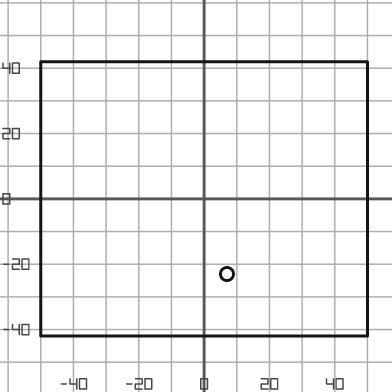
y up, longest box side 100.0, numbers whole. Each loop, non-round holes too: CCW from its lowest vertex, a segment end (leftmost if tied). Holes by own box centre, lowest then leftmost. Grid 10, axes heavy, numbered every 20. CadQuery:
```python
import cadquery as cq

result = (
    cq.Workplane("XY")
    .moveTo(-50.0, -42.0)
    .lineTo(50.0, -42.0)
    .lineTo(50.0, 42.0)
    .lineTo(-50.0, 42.0)
    .close()
    .moveTo(7.0, -23.0)
    .circle(2.0)
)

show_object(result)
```